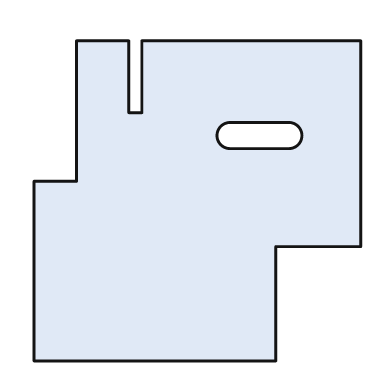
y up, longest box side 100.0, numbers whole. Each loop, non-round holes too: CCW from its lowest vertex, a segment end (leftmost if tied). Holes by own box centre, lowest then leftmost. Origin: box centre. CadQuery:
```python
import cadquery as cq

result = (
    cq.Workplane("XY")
    .moveTo(-50.0, -49.0)
    .lineTo(24.0, -49.0)
    .lineTo(24.0, -14.0)
    .lineTo(50.0, -14.0)
    .lineTo(50.0, 49.0)
    .lineTo(-17.0, 49.0)
    .lineTo(-17.0, 27.0)
    .lineTo(-21.0, 27.0)
    .lineTo(-21.0, 49.0)
    .lineTo(-37.0, 49.0)
    .lineTo(-37.0, 6.0)
    .lineTo(-50.0, 6.0)
    .close()
    .moveTo(10.0, 16.0)
    .lineTo(28.0, 16.0)
    .threePointArc((32.0, 20.0), (28.0, 24.0))
    .lineTo(10.0, 24.0)
    .threePointArc((6.0, 20.0), (10.0, 16.0))
    .close()
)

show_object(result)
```